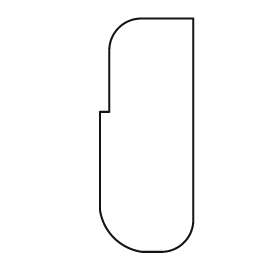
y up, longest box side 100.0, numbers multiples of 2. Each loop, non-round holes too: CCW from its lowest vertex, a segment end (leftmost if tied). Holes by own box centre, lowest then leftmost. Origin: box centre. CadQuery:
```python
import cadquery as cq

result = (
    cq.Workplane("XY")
    .moveTo(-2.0, -50.0)
    .lineTo(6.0, -50.0)
    .threePointArc((16.0, -46.0), (20.0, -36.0))
    .lineTo(20.0, 50.0)
    .lineTo(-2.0, 50.0)
    .threePointArc((-12.0, 46.0), (-16.0, 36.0))
    .lineTo(-16.0, 10.0)
    .lineTo(-20.0, 10.0)
    .lineTo(-20.0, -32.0)
    .threePointArc((-14.0, -44.0), (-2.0, -50.0))
    .close()
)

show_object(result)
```